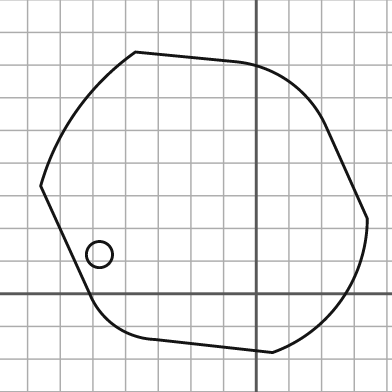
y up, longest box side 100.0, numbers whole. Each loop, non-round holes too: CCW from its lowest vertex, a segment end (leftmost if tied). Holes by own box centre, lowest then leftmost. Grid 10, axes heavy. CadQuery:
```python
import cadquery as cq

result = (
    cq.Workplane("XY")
    .moveTo(5.0, -18.0)
    .threePointArc((26.0, -2.0), (34.0, 23.0))
    .lineTo(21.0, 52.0)
    .threePointArc((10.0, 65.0), (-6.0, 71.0))
    .lineTo(-37.0, 74.0)
    .threePointArc((-55.0, 56.0), (-66.0, 33.0))
    .lineTo(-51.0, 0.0)
    .threePointArc((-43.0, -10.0), (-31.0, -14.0))
    .close()
    .moveTo(-48.0, 12.0)
    .circle(4.0)
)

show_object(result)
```